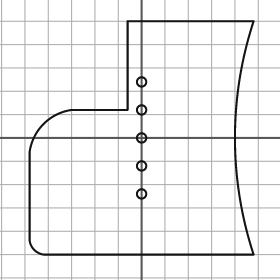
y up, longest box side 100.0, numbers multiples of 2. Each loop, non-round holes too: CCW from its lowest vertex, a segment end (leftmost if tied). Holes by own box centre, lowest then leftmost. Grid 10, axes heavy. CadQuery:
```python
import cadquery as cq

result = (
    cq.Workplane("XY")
    .moveTo(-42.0, -50.0)
    .lineTo(48.0, -50.0)
    .threePointArc((40.0, 0.0), (48.0, 50.0))
    .lineTo(-6.0, 50.0)
    .lineTo(-6.0, 12.0)
    .lineTo(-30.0, 12.0)
    .threePointArc((-42.0, 6.0), (-48.0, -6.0))
    .lineTo(-48.0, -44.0)
    .threePointArc((-46.0, -48.0), (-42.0, -50.0))
    .close()
    .moveTo(0.0, -24.0)
    .circle(2.0)
    .moveTo(0.0, -12.0)
    .circle(2.0)
    .moveTo(0.0, 0.0)
    .circle(2.0)
    .moveTo(0.0, 12.0)
    .circle(2.0)
    .moveTo(0.0, 24.0)
    .circle(2.0)
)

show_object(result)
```